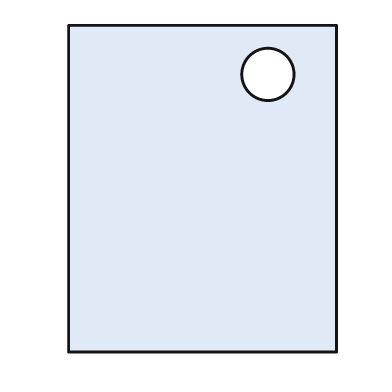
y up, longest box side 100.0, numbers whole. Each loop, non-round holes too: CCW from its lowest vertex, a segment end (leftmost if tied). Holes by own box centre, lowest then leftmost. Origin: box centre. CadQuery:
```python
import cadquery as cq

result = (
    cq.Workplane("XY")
    .moveTo(-41.0, -50.0)
    .lineTo(41.0, -50.0)
    .lineTo(41.0, 50.0)
    .lineTo(-41.0, 50.0)
    .close()
    .moveTo(20.0, 35.0)
    .circle(8.0)
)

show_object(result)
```